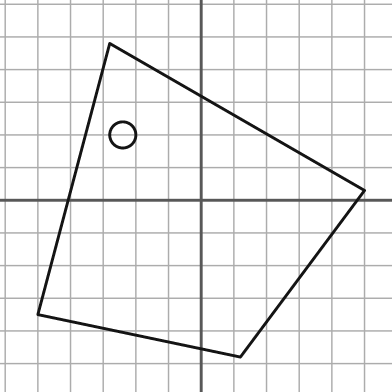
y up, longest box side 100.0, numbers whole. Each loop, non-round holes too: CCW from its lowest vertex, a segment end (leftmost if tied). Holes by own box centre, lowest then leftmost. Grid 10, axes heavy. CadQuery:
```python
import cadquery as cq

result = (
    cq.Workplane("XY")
    .moveTo(12.0, -48.0)
    .lineTo(50.0, 3.0)
    .lineTo(-28.0, 48.0)
    .lineTo(-50.0, -35.0)
    .close()
    .moveTo(-24.0, 20.0)
    .circle(4.0)
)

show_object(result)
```